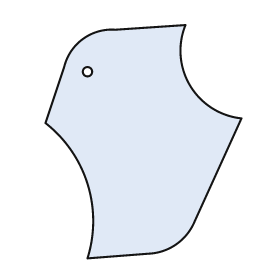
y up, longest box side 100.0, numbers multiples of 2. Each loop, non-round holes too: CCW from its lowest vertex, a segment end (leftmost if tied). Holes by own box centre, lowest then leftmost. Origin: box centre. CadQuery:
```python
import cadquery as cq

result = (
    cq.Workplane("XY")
    .moveTo(-24.0, -50.0)
    .lineTo(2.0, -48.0)
    .threePointArc((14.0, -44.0), (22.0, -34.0))
    .lineTo(42.0, 10.0)
    .threePointArc((20.0, 24.0), (18.0, 50.0))
    .lineTo(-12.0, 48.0)
    .threePointArc((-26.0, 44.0), (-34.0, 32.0))
    .lineTo(-42.0, 8.0)
    .threePointArc((-24.0, -18.0), (-24.0, -50.0))
    .close()
    .moveTo(-24.0, 30.0)
    .circle(2.0)
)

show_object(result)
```